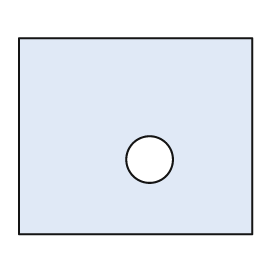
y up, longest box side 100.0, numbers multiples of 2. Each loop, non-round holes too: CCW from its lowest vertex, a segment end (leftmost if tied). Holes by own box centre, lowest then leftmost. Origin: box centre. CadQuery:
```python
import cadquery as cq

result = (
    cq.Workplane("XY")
    .moveTo(-50.0, -42.0)
    .lineTo(50.0, -42.0)
    .lineTo(50.0, 42.0)
    .lineTo(-50.0, 42.0)
    .close()
    .moveTo(6.0, -10.0)
    .circle(10.0)
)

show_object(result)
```